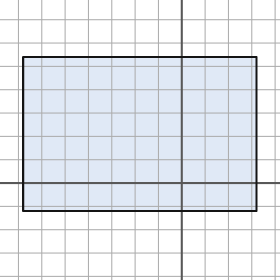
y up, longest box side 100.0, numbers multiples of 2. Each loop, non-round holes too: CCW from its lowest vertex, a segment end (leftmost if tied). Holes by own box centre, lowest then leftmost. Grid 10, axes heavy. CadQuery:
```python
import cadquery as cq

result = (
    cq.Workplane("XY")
    .moveTo(-68.0, -12.0)
    .lineTo(32.0, -12.0)
    .lineTo(32.0, 54.0)
    .lineTo(-68.0, 54.0)
    .close()
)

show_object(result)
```